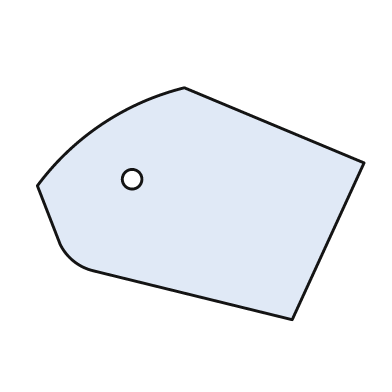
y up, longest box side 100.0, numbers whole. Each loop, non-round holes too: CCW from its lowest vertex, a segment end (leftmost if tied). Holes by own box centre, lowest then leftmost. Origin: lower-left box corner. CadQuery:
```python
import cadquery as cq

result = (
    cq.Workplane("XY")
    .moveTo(78.0, 0.0)
    .lineTo(100.0, 48.0)
    .lineTo(45.0, 71.0)
    .threePointArc((20.0, 60.0), (0.0, 41.0))
    .lineTo(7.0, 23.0)
    .threePointArc((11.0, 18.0), (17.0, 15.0))
    .close()
    .moveTo(29.0, 43.0)
    .circle(3.0)
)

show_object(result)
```